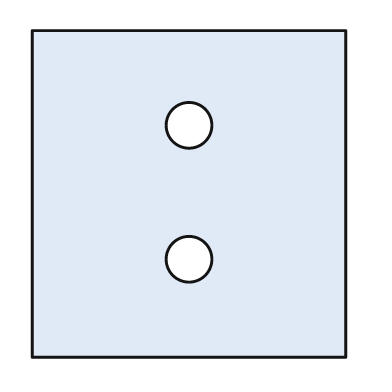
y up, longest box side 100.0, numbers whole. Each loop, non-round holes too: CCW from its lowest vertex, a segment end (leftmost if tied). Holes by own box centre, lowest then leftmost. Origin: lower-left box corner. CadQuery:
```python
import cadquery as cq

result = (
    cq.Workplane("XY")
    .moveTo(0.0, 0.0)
    .lineTo(96.0, 0.0)
    .lineTo(96.0, 100.0)
    .lineTo(0.0, 100.0)
    .close()
    .moveTo(48.0, 30.0)
    .circle(7.0)
    .moveTo(48.0, 71.0)
    .circle(7.0)
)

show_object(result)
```